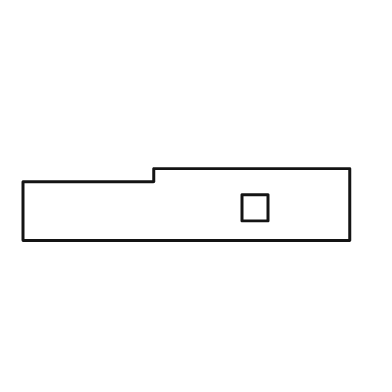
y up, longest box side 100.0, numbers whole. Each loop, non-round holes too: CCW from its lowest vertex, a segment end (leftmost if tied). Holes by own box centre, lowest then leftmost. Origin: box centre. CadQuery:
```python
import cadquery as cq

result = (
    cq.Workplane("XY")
    .moveTo(-50.0, -11.0)
    .lineTo(50.0, -11.0)
    .lineTo(50.0, 11.0)
    .lineTo(-10.0, 11.0)
    .lineTo(-10.0, 7.0)
    .lineTo(-50.0, 7.0)
    .close()
    .moveTo(17.0, -5.0)
    .lineTo(25.0, -5.0)
    .lineTo(25.0, 3.0)
    .lineTo(17.0, 3.0)
    .close()
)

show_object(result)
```